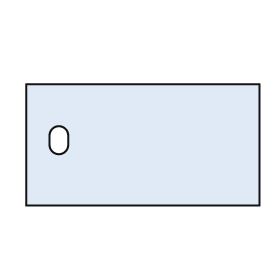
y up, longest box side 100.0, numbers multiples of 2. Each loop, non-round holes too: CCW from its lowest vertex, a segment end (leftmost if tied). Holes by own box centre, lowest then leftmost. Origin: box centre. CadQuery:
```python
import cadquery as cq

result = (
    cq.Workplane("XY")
    .moveTo(-50.0, -26.0)
    .lineTo(50.0, -26.0)
    .lineTo(50.0, 26.0)
    .lineTo(-50.0, 26.0)
    .close()
    .moveTo(-40.0, 0.0)
    .threePointArc((-36.0, -4.0), (-32.0, 0.0))
    .lineTo(-32.0, 4.0)
    .threePointArc((-36.0, 8.0), (-40.0, 4.0))
    .close()
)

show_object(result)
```